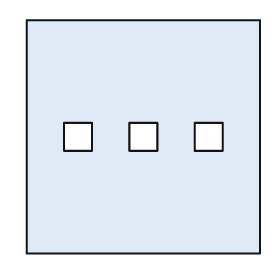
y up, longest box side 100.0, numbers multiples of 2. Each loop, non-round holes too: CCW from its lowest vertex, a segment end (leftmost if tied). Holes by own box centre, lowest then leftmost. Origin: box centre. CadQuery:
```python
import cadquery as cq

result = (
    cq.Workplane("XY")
    .moveTo(-50.0, -50.0)
    .lineTo(50.0, -50.0)
    .lineTo(50.0, 50.0)
    .lineTo(-50.0, 50.0)
    .close()
    .moveTo(-34.0, -6.0)
    .lineTo(-22.0, -6.0)
    .lineTo(-22.0, 6.0)
    .lineTo(-34.0, 6.0)
    .close()
    .moveTo(-6.0, -6.0)
    .lineTo(6.0, -6.0)
    .lineTo(6.0, 6.0)
    .lineTo(-6.0, 6.0)
    .close()
    .moveTo(22.0, -6.0)
    .lineTo(34.0, -6.0)
    .lineTo(34.0, 6.0)
    .lineTo(22.0, 6.0)
    .close()
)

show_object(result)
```